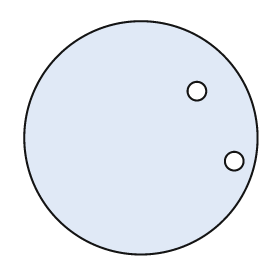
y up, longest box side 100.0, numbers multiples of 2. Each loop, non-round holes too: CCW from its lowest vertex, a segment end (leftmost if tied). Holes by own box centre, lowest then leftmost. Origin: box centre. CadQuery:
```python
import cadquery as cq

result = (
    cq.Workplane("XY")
    .moveTo(0.0, 0.0)
    .circle(50.0)
    .moveTo(40.0, -10.0)
    .circle(4.0)
    .moveTo(24.0, 20.0)
    .circle(4.0)
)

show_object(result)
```